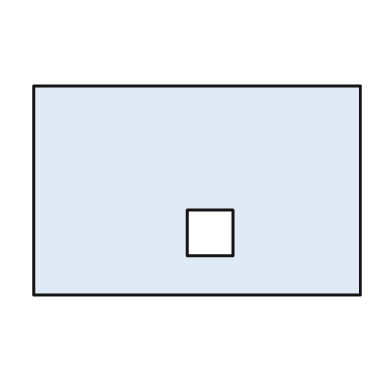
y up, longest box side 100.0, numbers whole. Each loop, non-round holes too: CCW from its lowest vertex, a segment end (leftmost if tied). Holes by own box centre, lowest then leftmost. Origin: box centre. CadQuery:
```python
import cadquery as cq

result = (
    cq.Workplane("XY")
    .moveTo(-50.0, -32.0)
    .lineTo(50.0, -32.0)
    .lineTo(50.0, 32.0)
    .lineTo(-50.0, 32.0)
    .close()
    .moveTo(-3.0, -20.0)
    .lineTo(11.0, -20.0)
    .lineTo(11.0, -6.0)
    .lineTo(-3.0, -6.0)
    .close()
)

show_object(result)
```